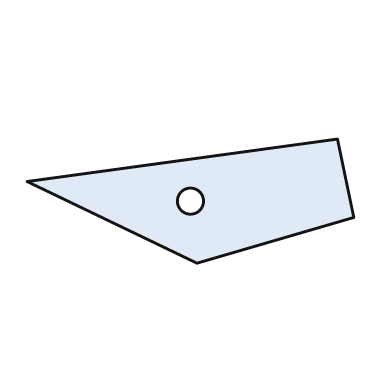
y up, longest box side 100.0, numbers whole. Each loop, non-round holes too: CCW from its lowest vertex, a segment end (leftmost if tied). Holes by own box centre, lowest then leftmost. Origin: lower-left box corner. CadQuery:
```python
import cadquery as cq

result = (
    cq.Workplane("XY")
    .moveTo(52.0, 0.0)
    .lineTo(100.0, 14.0)
    .lineTo(95.0, 38.0)
    .lineTo(0.0, 25.0)
    .close()
    .moveTo(50.0, 19.0)
    .circle(4.0)
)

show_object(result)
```